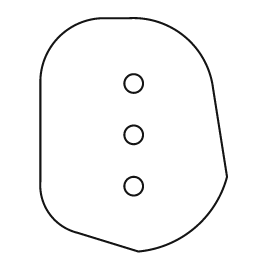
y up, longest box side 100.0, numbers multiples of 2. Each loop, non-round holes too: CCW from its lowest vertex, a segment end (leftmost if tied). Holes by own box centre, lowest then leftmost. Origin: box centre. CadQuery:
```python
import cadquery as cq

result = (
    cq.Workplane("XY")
    .moveTo(2.0, -50.0)
    .threePointArc((26.0, -40.0), (40.0, -18.0))
    .lineTo(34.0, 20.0)
    .threePointArc((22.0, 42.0), (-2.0, 50.0))
    .lineTo(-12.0, 50.0)
    .threePointArc((-32.0, 42.0), (-40.0, 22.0))
    .lineTo(-40.0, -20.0)
    .threePointArc((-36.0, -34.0), (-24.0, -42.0))
    .close()
    .moveTo(0.0, -22.0)
    .circle(4.0)
    .moveTo(0.0, 0.0)
    .circle(4.0)
    .moveTo(0.0, 22.0)
    .circle(4.0)
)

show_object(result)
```